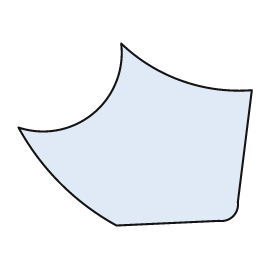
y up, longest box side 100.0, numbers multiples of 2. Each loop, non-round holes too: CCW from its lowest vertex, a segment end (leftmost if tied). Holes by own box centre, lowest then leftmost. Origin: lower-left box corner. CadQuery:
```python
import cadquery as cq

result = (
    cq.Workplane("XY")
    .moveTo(42.0, 0.0)
    .lineTo(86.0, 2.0)
    .threePointArc((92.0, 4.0), (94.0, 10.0))
    .lineTo(100.0, 58.0)
    .threePointArc((70.0, 62.0), (44.0, 78.0))
    .threePointArc((32.0, 48.0), (0.0, 42.0))
    .threePointArc((18.0, 18.0), (42.0, 0.0))
    .close()
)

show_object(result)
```